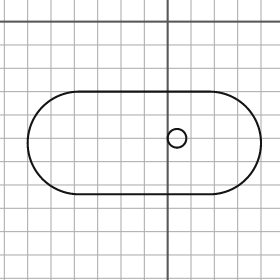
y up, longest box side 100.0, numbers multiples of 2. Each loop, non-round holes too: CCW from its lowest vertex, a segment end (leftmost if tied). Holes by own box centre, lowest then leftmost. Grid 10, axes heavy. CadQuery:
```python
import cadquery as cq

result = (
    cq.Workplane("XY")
    .moveTo(-38.0, -74.0)
    .lineTo(18.0, -74.0)
    .threePointArc((40.0, -52.0), (18.0, -30.0))
    .lineTo(-38.0, -30.0)
    .threePointArc((-60.0, -52.0), (-38.0, -74.0))
    .close()
    .moveTo(4.0, -50.0)
    .circle(4.0)
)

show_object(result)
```